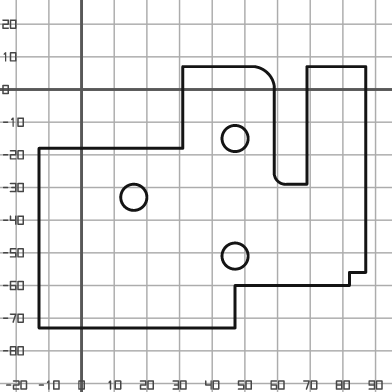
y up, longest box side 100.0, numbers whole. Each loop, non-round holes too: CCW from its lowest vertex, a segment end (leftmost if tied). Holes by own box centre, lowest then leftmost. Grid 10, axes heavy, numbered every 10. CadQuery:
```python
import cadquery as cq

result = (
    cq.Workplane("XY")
    .moveTo(-13.0, -73.0)
    .lineTo(47.0, -73.0)
    .lineTo(47.0, -60.0)
    .lineTo(82.0, -60.0)
    .lineTo(82.0, -56.0)
    .lineTo(87.0, -56.0)
    .lineTo(87.0, 7.0)
    .lineTo(69.0, 7.0)
    .lineTo(69.0, -29.0)
    .lineTo(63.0, -29.0)
    .threePointArc((60.0, -28.0), (59.0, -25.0))
    .lineTo(59.0, 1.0)
    .threePointArc((57.0, 5.0), (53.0, 7.0))
    .lineTo(31.0, 7.0)
    .lineTo(31.0, -18.0)
    .lineTo(-13.0, -18.0)
    .close()
    .moveTo(47.0, -51.0)
    .circle(4.0)
    .moveTo(16.0, -33.0)
    .circle(4.0)
    .moveTo(47.0, -15.0)
    .circle(4.0)
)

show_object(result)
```